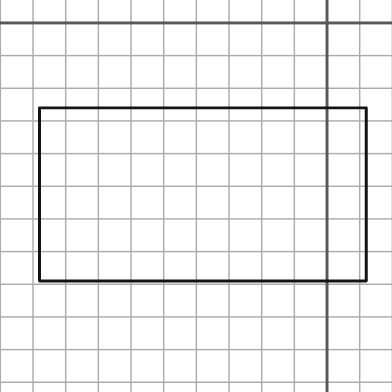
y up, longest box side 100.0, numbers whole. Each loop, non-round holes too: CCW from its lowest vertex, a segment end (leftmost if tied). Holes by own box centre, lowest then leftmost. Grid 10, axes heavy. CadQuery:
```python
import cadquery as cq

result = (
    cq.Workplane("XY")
    .moveTo(-88.0, -79.0)
    .lineTo(12.0, -79.0)
    .lineTo(12.0, -26.0)
    .lineTo(-88.0, -26.0)
    .close()
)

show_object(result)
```